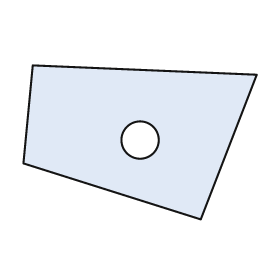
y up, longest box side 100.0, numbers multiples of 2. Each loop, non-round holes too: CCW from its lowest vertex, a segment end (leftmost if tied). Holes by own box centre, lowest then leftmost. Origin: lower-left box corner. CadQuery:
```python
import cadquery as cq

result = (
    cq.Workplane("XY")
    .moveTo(76.0, 0.0)
    .lineTo(100.0, 62.0)
    .lineTo(4.0, 66.0)
    .lineTo(0.0, 24.0)
    .close()
    .moveTo(50.0, 34.0)
    .circle(8.0)
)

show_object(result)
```